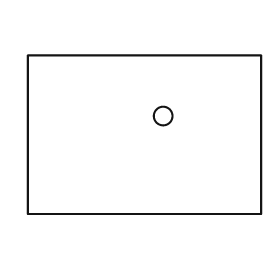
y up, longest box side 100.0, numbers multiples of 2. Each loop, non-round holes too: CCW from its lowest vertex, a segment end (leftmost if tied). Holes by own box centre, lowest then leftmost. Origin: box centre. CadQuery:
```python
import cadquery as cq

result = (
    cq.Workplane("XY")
    .moveTo(-50.0, -34.0)
    .lineTo(50.0, -34.0)
    .lineTo(50.0, 34.0)
    .lineTo(-50.0, 34.0)
    .close()
    .moveTo(8.0, 8.0)
    .circle(4.0)
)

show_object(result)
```